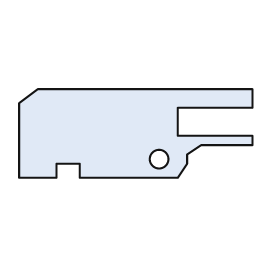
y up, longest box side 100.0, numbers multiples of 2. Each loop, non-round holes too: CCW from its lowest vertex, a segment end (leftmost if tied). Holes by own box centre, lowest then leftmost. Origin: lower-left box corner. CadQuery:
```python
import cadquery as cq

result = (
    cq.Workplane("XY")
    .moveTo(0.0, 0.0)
    .lineTo(16.0, 0.0)
    .lineTo(16.0, 6.0)
    .lineTo(26.0, 6.0)
    .lineTo(26.0, 0.0)
    .lineTo(68.0, 0.0)
    .lineTo(72.0, 6.0)
    .lineTo(72.0, 10.0)
    .lineTo(78.0, 14.0)
    .lineTo(100.0, 14.0)
    .lineTo(100.0, 18.0)
    .lineTo(68.0, 18.0)
    .lineTo(68.0, 30.0)
    .lineTo(100.0, 30.0)
    .lineTo(100.0, 38.0)
    .lineTo(8.0, 38.0)
    .lineTo(0.0, 32.0)
    .close()
    .moveTo(60.0, 8.0)
    .circle(4.0)
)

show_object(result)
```